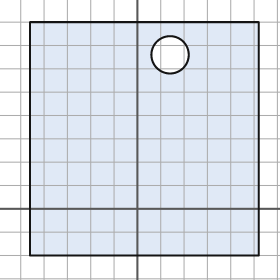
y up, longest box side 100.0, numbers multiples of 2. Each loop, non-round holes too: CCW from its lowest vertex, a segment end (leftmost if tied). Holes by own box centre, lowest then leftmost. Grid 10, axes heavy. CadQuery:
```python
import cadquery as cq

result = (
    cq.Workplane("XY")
    .moveTo(-46.0, -20.0)
    .lineTo(52.0, -20.0)
    .lineTo(52.0, 80.0)
    .lineTo(-46.0, 80.0)
    .close()
    .moveTo(14.0, 66.0)
    .circle(8.0)
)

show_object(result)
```